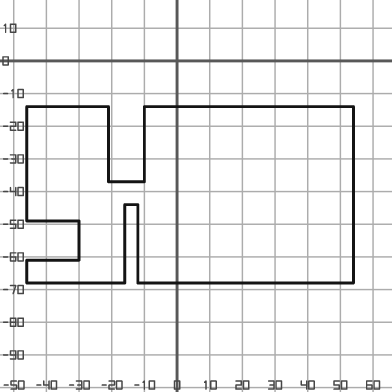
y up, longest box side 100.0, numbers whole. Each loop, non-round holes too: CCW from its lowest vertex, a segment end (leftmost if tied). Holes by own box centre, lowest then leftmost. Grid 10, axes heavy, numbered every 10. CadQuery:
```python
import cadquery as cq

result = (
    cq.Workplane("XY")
    .moveTo(-46.0, -68.0)
    .lineTo(-16.0, -68.0)
    .lineTo(-16.0, -44.0)
    .lineTo(-12.0, -44.0)
    .lineTo(-12.0, -68.0)
    .lineTo(54.0, -68.0)
    .lineTo(54.0, -14.0)
    .lineTo(-10.0, -14.0)
    .lineTo(-10.0, -37.0)
    .lineTo(-21.0, -37.0)
    .lineTo(-21.0, -14.0)
    .lineTo(-46.0, -14.0)
    .lineTo(-46.0, -49.0)
    .lineTo(-30.0, -49.0)
    .lineTo(-30.0, -61.0)
    .lineTo(-46.0, -61.0)
    .close()
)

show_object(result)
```